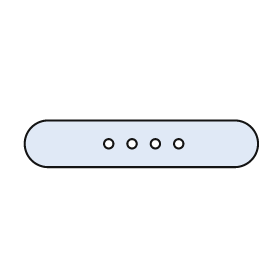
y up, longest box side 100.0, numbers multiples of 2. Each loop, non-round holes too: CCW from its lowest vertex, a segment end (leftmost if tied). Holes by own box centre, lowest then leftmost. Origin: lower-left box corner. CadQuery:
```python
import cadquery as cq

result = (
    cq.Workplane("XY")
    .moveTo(10.0, 0.0)
    .lineTo(90.0, 0.0)
    .threePointArc((100.0, 10.0), (90.0, 20.0))
    .lineTo(10.0, 20.0)
    .threePointArc((0.0, 10.0), (10.0, 0.0))
    .close()
    .moveTo(36.0, 10.0)
    .circle(2.0)
    .moveTo(46.0, 10.0)
    .circle(2.0)
    .moveTo(56.0, 10.0)
    .circle(2.0)
    .moveTo(66.0, 10.0)
    .circle(2.0)
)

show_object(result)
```